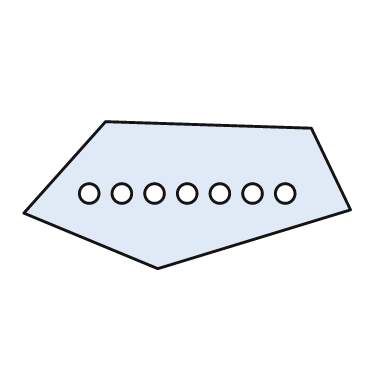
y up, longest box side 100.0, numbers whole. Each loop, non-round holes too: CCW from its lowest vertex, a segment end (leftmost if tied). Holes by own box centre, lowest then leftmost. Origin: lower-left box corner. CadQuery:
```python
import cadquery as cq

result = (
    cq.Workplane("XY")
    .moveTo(41.0, 0.0)
    .lineTo(100.0, 18.0)
    .lineTo(88.0, 43.0)
    .lineTo(25.0, 45.0)
    .lineTo(0.0, 17.0)
    .close()
    .moveTo(20.0, 23.0)
    .circle(3.0)
    .moveTo(30.0, 23.0)
    .circle(3.0)
    .moveTo(40.0, 23.0)
    .circle(3.0)
    .moveTo(50.0, 23.0)
    .circle(3.0)
    .moveTo(60.0, 23.0)
    .circle(3.0)
    .moveTo(70.0, 23.0)
    .circle(3.0)
    .moveTo(80.0, 23.0)
    .circle(3.0)
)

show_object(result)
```